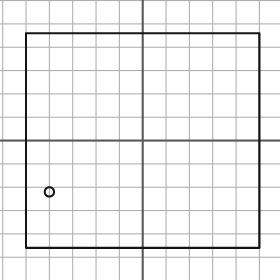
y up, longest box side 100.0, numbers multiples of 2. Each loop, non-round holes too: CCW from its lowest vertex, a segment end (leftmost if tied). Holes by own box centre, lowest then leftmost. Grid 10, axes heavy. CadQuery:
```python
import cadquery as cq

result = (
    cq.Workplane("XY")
    .moveTo(-50.0, -46.0)
    .lineTo(50.0, -46.0)
    .lineTo(50.0, 46.0)
    .lineTo(-50.0, 46.0)
    .close()
    .moveTo(-40.0, -22.0)
    .circle(2.0)
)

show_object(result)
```